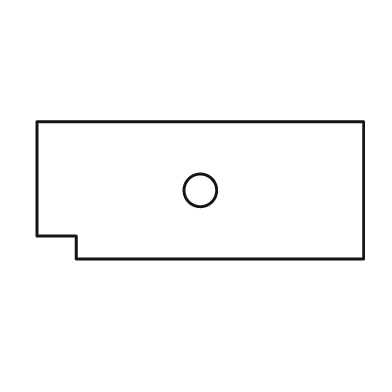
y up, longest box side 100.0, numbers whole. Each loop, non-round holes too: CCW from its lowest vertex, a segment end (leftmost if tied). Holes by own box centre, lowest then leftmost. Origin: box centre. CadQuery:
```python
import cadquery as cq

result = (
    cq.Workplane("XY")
    .moveTo(-38.0, -21.0)
    .lineTo(50.0, -21.0)
    .lineTo(50.0, 21.0)
    .lineTo(-50.0, 21.0)
    .lineTo(-50.0, -14.0)
    .lineTo(-38.0, -14.0)
    .close()
    .moveTo(0.0, 0.0)
    .circle(5.0)
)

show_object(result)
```